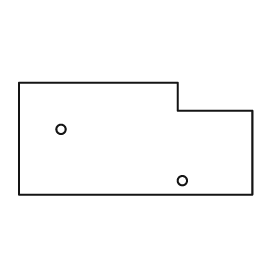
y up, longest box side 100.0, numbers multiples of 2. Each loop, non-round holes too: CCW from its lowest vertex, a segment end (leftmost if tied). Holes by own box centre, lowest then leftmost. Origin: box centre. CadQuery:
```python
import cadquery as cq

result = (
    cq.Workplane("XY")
    .moveTo(-50.0, -24.0)
    .lineTo(50.0, -24.0)
    .lineTo(50.0, 12.0)
    .lineTo(18.0, 12.0)
    .lineTo(18.0, 24.0)
    .lineTo(-50.0, 24.0)
    .close()
    .moveTo(20.0, -18.0)
    .circle(2.0)
    .moveTo(-32.0, 4.0)
    .circle(2.0)
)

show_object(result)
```